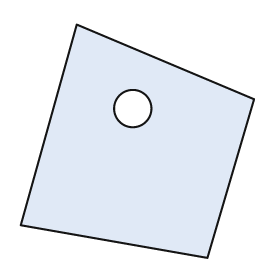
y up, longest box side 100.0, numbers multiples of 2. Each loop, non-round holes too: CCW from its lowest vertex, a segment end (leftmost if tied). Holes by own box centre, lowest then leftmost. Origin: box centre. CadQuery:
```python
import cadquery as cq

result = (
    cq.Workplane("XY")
    .moveTo(30.0, -50.0)
    .lineTo(50.0, 18.0)
    .lineTo(-26.0, 50.0)
    .lineTo(-50.0, -36.0)
    .close()
    .moveTo(-2.0, 14.0)
    .circle(8.0)
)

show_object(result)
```